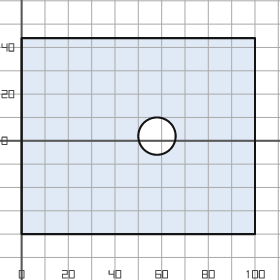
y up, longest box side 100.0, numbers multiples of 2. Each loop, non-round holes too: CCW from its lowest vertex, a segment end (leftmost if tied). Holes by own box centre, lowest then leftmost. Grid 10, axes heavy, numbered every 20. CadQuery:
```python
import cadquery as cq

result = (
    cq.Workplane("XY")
    .moveTo(0.0, -40.0)
    .lineTo(100.0, -40.0)
    .lineTo(100.0, 44.0)
    .lineTo(0.0, 44.0)
    .close()
    .moveTo(58.0, 2.0)
    .circle(8.0)
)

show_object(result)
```